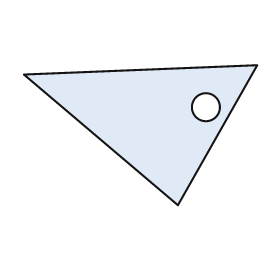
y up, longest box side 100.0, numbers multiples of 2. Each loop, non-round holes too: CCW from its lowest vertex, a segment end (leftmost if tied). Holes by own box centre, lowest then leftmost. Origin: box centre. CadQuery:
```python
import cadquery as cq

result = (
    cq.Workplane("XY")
    .moveTo(16.0, -30.0)
    .lineTo(50.0, 30.0)
    .lineTo(-50.0, 26.0)
    .close()
    .moveTo(28.0, 12.0)
    .circle(6.0)
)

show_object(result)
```